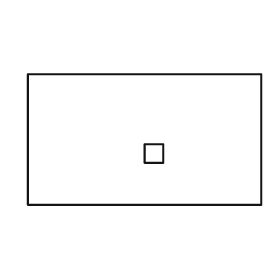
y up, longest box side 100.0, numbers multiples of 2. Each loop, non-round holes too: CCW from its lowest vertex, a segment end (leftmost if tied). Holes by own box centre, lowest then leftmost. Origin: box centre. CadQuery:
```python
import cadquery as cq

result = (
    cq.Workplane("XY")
    .moveTo(-50.0, -28.0)
    .lineTo(50.0, -28.0)
    .lineTo(50.0, 28.0)
    .lineTo(-50.0, 28.0)
    .close()
    .moveTo(0.0, -10.0)
    .lineTo(8.0, -10.0)
    .lineTo(8.0, -2.0)
    .lineTo(0.0, -2.0)
    .close()
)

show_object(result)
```